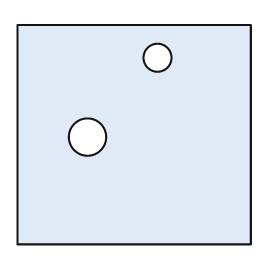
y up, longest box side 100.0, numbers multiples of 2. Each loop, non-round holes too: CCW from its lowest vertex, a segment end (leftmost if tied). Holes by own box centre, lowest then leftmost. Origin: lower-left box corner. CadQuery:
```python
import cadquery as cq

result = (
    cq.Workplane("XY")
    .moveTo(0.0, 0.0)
    .lineTo(100.0, 0.0)
    .lineTo(100.0, 94.0)
    .lineTo(0.0, 94.0)
    .close()
    .moveTo(30.0, 46.0)
    .circle(8.0)
    .moveTo(60.0, 80.0)
    .circle(6.0)
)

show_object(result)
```